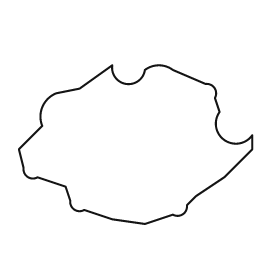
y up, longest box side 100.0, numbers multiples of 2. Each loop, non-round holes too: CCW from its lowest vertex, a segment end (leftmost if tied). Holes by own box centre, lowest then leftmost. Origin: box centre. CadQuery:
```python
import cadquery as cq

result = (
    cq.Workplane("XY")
    .moveTo(4.0, -34.0)
    .lineTo(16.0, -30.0)
    .threePointArc((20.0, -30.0), (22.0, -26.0))
    .lineTo(26.0, -22.0)
    .lineTo(38.0, -14.0)
    .lineTo(50.0, -2.0)
    .lineTo(50.0, 4.0)
    .threePointArc((38.0, 2.0), (36.0, 14.0))
    .lineTo(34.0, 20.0)
    .threePointArc((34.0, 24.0), (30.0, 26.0))
    .lineTo(16.0, 32.0)
    .threePointArc((10.0, 34.0), (4.0, 32.0))
    .threePointArc((-4.0, 26.0), (-10.0, 34.0))
    .lineTo(-24.0, 24.0)
    .lineTo(-34.0, 22.0)
    .threePointArc((-40.0, 16.0), (-40.0, 8.0))
    .lineTo(-50.0, -2.0)
    .lineTo(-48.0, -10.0)
    .threePointArc((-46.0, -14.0), (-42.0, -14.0))
    .lineTo(-30.0, -18.0)
    .lineTo(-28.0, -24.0)
    .threePointArc((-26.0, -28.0), (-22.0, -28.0))
    .lineTo(-10.0, -32.0)
    .close()
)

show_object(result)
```